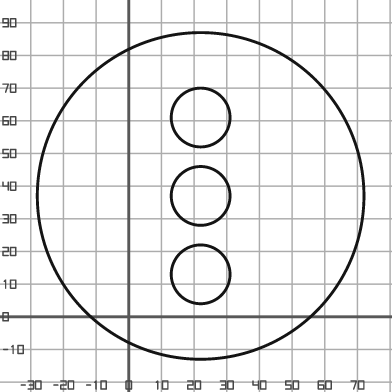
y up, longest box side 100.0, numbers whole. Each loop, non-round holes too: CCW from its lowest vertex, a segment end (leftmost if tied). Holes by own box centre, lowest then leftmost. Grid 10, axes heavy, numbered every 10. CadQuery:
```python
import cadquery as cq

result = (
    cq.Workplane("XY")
    .moveTo(22.0, 37.0)
    .circle(50.0)
    .moveTo(22.0, 13.0)
    .circle(9.0)
    .moveTo(22.0, 37.0)
    .circle(9.0)
    .moveTo(22.0, 61.0)
    .circle(9.0)
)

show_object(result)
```